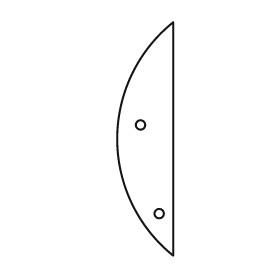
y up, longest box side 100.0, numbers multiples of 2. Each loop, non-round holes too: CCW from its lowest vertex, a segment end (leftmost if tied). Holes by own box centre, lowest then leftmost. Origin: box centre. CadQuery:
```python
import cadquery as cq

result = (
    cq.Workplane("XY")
    .moveTo(12.0, -50.0)
    .lineTo(12.0, 50.0)
    .threePointArc((-12.0, 0.0), (12.0, -50.0))
    .close()
    .moveTo(6.0, -32.0)
    .circle(2.0)
    .moveTo(-2.0, 6.0)
    .circle(2.0)
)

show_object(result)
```